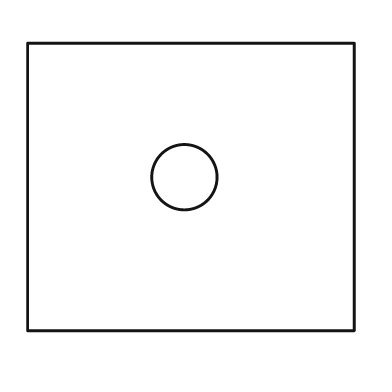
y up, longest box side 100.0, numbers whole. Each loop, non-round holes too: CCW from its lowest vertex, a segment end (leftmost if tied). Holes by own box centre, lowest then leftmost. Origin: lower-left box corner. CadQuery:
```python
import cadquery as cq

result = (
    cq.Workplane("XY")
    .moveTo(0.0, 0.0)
    .lineTo(100.0, 0.0)
    .lineTo(100.0, 88.0)
    .lineTo(0.0, 88.0)
    .close()
    .moveTo(48.0, 47.0)
    .circle(10.0)
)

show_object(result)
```